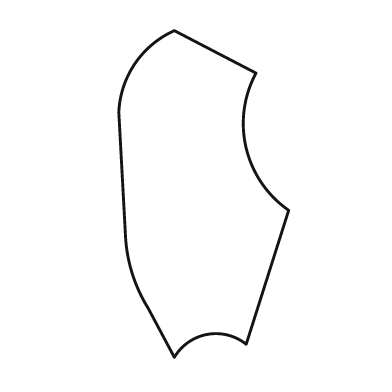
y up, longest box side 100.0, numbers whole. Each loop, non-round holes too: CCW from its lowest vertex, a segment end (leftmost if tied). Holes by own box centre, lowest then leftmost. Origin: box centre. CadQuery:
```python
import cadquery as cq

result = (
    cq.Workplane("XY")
    .moveTo(-9.0, -50.0)
    .threePointArc((1.0, -43.0), (13.0, -46.0))
    .lineTo(26.0, -5.0)
    .threePointArc((13.0, 14.0), (16.0, 37.0))
    .lineTo(-9.0, 50.0)
    .threePointArc((-21.0, 40.0), (-26.0, 25.0))
    .lineTo(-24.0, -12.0)
    .threePointArc((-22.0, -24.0), (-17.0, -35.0))
    .close()
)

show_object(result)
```